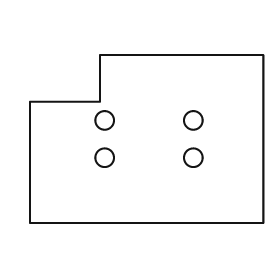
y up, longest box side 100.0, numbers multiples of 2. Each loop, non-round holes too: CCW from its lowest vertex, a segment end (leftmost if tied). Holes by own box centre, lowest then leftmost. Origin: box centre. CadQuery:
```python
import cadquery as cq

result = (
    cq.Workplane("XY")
    .moveTo(-50.0, -36.0)
    .lineTo(50.0, -36.0)
    .lineTo(50.0, 36.0)
    .lineTo(-20.0, 36.0)
    .lineTo(-20.0, 16.0)
    .lineTo(-50.0, 16.0)
    .close()
    .moveTo(-18.0, -8.0)
    .circle(4.0)
    .moveTo(20.0, -8.0)
    .circle(4.0)
    .moveTo(-18.0, 8.0)
    .circle(4.0)
    .moveTo(20.0, 8.0)
    .circle(4.0)
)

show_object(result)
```